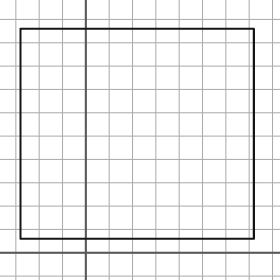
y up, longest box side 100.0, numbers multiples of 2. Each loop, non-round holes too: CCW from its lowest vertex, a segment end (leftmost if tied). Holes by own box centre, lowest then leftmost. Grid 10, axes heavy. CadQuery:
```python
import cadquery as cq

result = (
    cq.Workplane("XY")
    .moveTo(-28.0, 6.0)
    .lineTo(72.0, 6.0)
    .lineTo(72.0, 96.0)
    .lineTo(-28.0, 96.0)
    .close()
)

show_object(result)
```